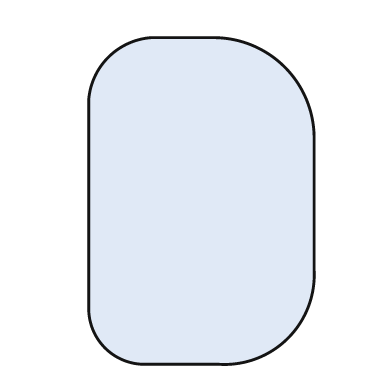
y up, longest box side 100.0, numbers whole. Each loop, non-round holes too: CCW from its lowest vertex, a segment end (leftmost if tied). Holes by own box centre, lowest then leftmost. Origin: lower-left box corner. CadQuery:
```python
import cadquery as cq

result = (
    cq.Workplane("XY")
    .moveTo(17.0, 0.0)
    .lineTo(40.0, 0.0)
    .threePointArc((61.0, 8.0), (69.0, 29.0))
    .lineTo(69.0, 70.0)
    .threePointArc((60.0, 91.0), (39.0, 100.0))
    .lineTo(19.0, 100.0)
    .threePointArc((6.0, 94.0), (0.0, 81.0))
    .lineTo(0.0, 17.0)
    .threePointArc((5.0, 5.0), (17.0, 0.0))
    .close()
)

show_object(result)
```